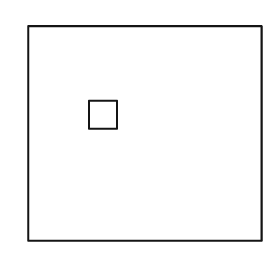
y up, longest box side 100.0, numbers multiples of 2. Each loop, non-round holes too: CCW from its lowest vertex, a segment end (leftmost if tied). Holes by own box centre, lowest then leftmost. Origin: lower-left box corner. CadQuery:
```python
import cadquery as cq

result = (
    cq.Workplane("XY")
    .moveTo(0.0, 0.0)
    .lineTo(100.0, 0.0)
    .lineTo(100.0, 92.0)
    .lineTo(0.0, 92.0)
    .close()
    .moveTo(26.0, 48.0)
    .lineTo(38.0, 48.0)
    .lineTo(38.0, 60.0)
    .lineTo(26.0, 60.0)
    .close()
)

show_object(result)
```